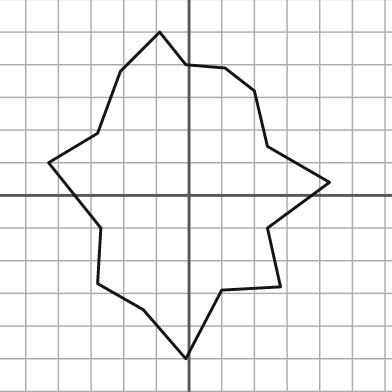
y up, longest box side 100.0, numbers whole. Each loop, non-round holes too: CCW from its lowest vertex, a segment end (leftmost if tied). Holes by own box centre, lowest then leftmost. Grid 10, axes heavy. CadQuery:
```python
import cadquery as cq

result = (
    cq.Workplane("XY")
    .moveTo(-1.0, -50.0)
    .lineTo(10.0, -29.0)
    .lineTo(28.0, -28.0)
    .lineTo(24.0, -10.0)
    .lineTo(43.0, 4.0)
    .lineTo(24.0, 15.0)
    .lineTo(20.0, 32.0)
    .lineTo(11.0, 39.0)
    .lineTo(-1.0, 40.0)
    .lineTo(-9.0, 50.0)
    .lineTo(-21.0, 38.0)
    .lineTo(-28.0, 19.0)
    .lineTo(-43.0, 10.0)
    .lineTo(-27.0, -10.0)
    .lineTo(-28.0, -27.0)
    .lineTo(-14.0, -35.0)
    .close()
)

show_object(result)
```